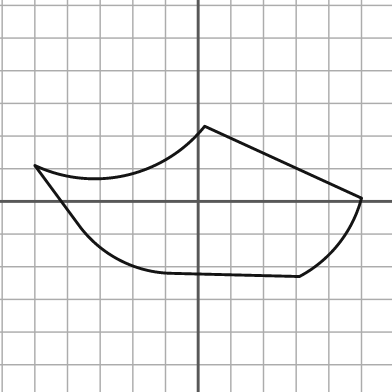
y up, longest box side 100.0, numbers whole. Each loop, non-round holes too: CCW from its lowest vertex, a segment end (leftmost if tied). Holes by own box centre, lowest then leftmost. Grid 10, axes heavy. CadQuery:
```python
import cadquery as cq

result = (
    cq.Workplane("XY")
    .moveTo(31.0, -23.0)
    .threePointArc((43.0, -13.0), (50.0, 1.0))
    .lineTo(2.0, 23.0)
    .threePointArc((-22.0, 8.0), (-50.0, 11.0))
    .lineTo(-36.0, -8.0)
    .threePointArc((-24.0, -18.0), (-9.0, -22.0))
    .close()
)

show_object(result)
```